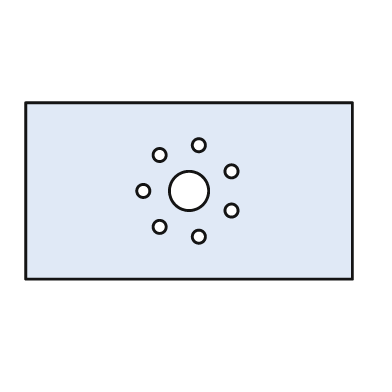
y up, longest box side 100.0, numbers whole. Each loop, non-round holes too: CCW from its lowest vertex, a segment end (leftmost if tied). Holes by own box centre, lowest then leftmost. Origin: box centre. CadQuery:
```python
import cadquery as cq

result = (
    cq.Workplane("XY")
    .moveTo(-50.0, -27.0)
    .lineTo(50.0, -27.0)
    .lineTo(50.0, 27.0)
    .lineTo(-50.0, 27.0)
    .close()
    .moveTo(3.0, -14.0)
    .circle(2.0)
    .moveTo(-9.0, -11.0)
    .circle(2.0)
    .moveTo(13.0, -6.0)
    .circle(2.0)
    .moveTo(-14.0, 0.0)
    .circle(2.0)
    .moveTo(0.0, 0.0)
    .circle(6.0)
    .moveTo(13.0, 6.0)
    .circle(2.0)
    .moveTo(-9.0, 11.0)
    .circle(2.0)
    .moveTo(3.0, 14.0)
    .circle(2.0)
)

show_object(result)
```